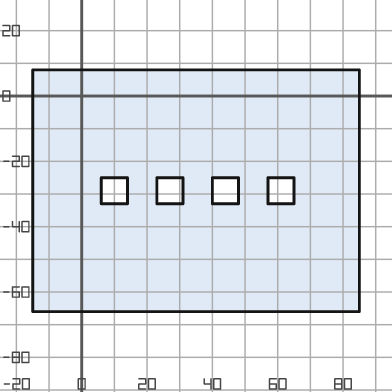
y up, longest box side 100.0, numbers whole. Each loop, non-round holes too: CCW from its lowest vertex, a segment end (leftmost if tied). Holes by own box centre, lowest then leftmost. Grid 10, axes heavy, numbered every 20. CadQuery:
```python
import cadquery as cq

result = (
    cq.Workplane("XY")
    .moveTo(-15.0, -66.0)
    .lineTo(85.0, -66.0)
    .lineTo(85.0, 8.0)
    .lineTo(-15.0, 8.0)
    .close()
    .moveTo(6.0, -33.0)
    .lineTo(14.0, -33.0)
    .lineTo(14.0, -25.0)
    .lineTo(6.0, -25.0)
    .close()
    .moveTo(23.0, -33.0)
    .lineTo(31.0, -33.0)
    .lineTo(31.0, -25.0)
    .lineTo(23.0, -25.0)
    .close()
    .moveTo(40.0, -33.0)
    .lineTo(48.0, -33.0)
    .lineTo(48.0, -25.0)
    .lineTo(40.0, -25.0)
    .close()
    .moveTo(57.0, -33.0)
    .lineTo(65.0, -33.0)
    .lineTo(65.0, -25.0)
    .lineTo(57.0, -25.0)
    .close()
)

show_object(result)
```